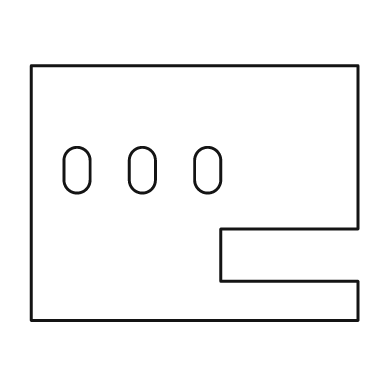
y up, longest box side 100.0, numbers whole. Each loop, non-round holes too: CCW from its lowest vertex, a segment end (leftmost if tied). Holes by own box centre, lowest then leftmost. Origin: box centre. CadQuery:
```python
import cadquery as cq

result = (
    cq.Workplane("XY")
    .moveTo(-50.0, -39.0)
    .lineTo(50.0, -39.0)
    .lineTo(50.0, -27.0)
    .lineTo(8.0, -27.0)
    .lineTo(8.0, -11.0)
    .lineTo(50.0, -11.0)
    .lineTo(50.0, 39.0)
    .lineTo(-50.0, 39.0)
    .close()
    .moveTo(-40.0, 4.0)
    .threePointArc((-36.0, 0.0), (-32.0, 4.0))
    .lineTo(-32.0, 10.0)
    .threePointArc((-36.0, 14.0), (-40.0, 10.0))
    .close()
    .moveTo(-20.0, 4.0)
    .threePointArc((-16.0, 0.0), (-12.0, 4.0))
    .lineTo(-12.0, 10.0)
    .threePointArc((-16.0, 14.0), (-20.0, 10.0))
    .close()
    .moveTo(0.0, 4.0)
    .threePointArc((4.0, 0.0), (8.0, 4.0))
    .lineTo(8.0, 10.0)
    .threePointArc((4.0, 14.0), (0.0, 10.0))
    .close()
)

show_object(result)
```